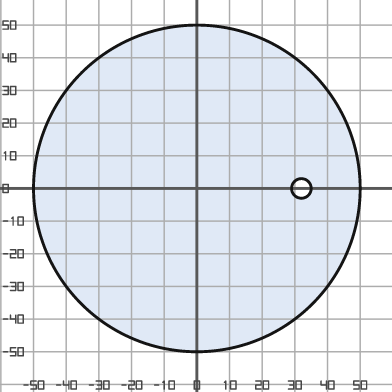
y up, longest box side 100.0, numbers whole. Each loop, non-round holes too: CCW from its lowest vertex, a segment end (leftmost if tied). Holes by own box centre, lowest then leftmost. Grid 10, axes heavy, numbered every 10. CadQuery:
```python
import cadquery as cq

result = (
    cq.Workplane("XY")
    .moveTo(0.0, 0.0)
    .circle(50.0)
    .moveTo(32.0, 0.0)
    .circle(3.0)
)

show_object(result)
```